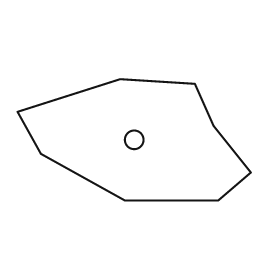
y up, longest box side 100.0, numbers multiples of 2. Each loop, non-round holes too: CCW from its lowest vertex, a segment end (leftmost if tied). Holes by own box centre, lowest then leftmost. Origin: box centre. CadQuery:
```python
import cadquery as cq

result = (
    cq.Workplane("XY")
    .moveTo(-4.0, -26.0)
    .lineTo(36.0, -26.0)
    .lineTo(50.0, -14.0)
    .lineTo(34.0, 6.0)
    .lineTo(26.0, 24.0)
    .lineTo(-6.0, 26.0)
    .lineTo(-50.0, 12.0)
    .lineTo(-40.0, -6.0)
    .close()
    .moveTo(0.0, 0.0)
    .circle(4.0)
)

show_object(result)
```